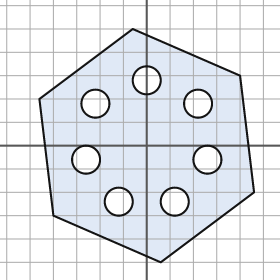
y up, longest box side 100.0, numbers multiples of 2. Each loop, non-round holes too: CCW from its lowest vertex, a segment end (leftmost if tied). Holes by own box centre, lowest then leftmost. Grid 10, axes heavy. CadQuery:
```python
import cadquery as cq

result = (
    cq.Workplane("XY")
    .moveTo(6.0, -50.0)
    .lineTo(46.0, -20.0)
    .lineTo(40.0, 30.0)
    .lineTo(-6.0, 50.0)
    .lineTo(-46.0, 20.0)
    .lineTo(-40.0, -30.0)
    .close()
    .moveTo(-12.0, -24.0)
    .circle(6.0)
    .moveTo(12.0, -24.0)
    .circle(6.0)
    .moveTo(-26.0, -6.0)
    .circle(6.0)
    .moveTo(26.0, -6.0)
    .circle(6.0)
    .moveTo(-22.0, 18.0)
    .circle(6.0)
    .moveTo(22.0, 18.0)
    .circle(6.0)
    .moveTo(0.0, 28.0)
    .circle(6.0)
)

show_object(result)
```